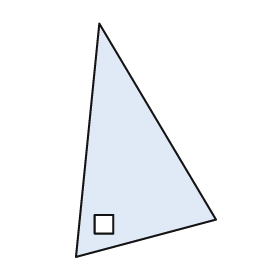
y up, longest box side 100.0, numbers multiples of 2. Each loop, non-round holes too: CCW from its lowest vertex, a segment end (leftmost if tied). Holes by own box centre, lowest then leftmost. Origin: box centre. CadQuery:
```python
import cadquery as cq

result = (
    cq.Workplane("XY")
    .moveTo(-30.0, -50.0)
    .lineTo(30.0, -34.0)
    .lineTo(-20.0, 50.0)
    .close()
    .moveTo(-22.0, -40.0)
    .lineTo(-14.0, -40.0)
    .lineTo(-14.0, -32.0)
    .lineTo(-22.0, -32.0)
    .close()
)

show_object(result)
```